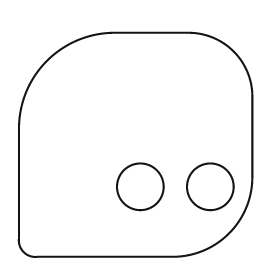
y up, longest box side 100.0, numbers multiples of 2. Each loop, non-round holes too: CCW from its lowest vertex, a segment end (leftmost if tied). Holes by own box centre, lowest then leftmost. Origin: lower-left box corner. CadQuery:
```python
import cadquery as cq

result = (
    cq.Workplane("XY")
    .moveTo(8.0, 0.0)
    .lineTo(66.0, 0.0)
    .threePointArc((90.0, 10.0), (100.0, 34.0))
    .lineTo(100.0, 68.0)
    .threePointArc((92.0, 88.0), (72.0, 96.0))
    .lineTo(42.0, 96.0)
    .threePointArc((12.0, 84.0), (0.0, 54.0))
    .lineTo(0.0, 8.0)
    .threePointArc((2.0, 2.0), (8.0, 0.0))
    .close()
    .moveTo(52.0, 30.0)
    .circle(10.0)
    .moveTo(82.0, 30.0)
    .circle(10.0)
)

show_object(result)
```